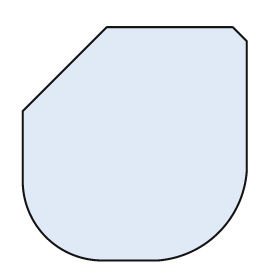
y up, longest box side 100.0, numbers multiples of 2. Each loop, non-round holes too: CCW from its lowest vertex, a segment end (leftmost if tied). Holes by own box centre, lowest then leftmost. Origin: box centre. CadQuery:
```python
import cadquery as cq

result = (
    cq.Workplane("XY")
    .moveTo(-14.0, -50.0)
    .lineTo(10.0, -50.0)
    .threePointArc((36.0, -38.0), (48.0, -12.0))
    .lineTo(48.0, 44.0)
    .lineTo(42.0, 50.0)
    .lineTo(-12.0, 50.0)
    .lineTo(-48.0, 14.0)
    .lineTo(-48.0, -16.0)
    .threePointArc((-38.0, -40.0), (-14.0, -50.0))
    .close()
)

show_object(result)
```